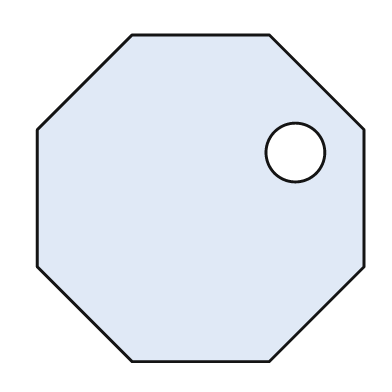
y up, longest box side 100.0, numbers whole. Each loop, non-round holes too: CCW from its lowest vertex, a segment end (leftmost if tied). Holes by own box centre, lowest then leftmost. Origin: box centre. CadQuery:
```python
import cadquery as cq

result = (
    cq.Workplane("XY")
    .moveTo(-21.0, -50.0)
    .lineTo(21.0, -50.0)
    .lineTo(50.0, -21.0)
    .lineTo(50.0, 21.0)
    .lineTo(21.0, 50.0)
    .lineTo(-21.0, 50.0)
    .lineTo(-50.0, 21.0)
    .lineTo(-50.0, -21.0)
    .close()
    .moveTo(29.0, 14.0)
    .circle(9.0)
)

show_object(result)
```